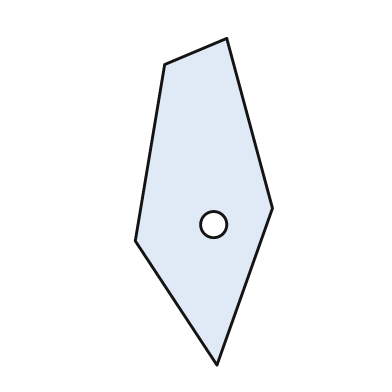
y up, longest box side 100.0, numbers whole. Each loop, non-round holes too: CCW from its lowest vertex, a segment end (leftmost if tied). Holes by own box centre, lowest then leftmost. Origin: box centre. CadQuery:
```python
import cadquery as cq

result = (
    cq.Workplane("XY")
    .moveTo(4.0, -50.0)
    .lineTo(21.0, -2.0)
    .lineTo(7.0, 50.0)
    .lineTo(-12.0, 42.0)
    .lineTo(-21.0, -12.0)
    .close()
    .moveTo(3.0, -7.0)
    .circle(4.0)
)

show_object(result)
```